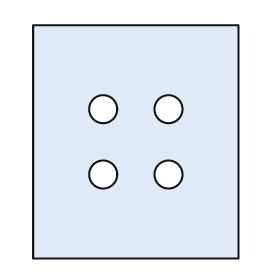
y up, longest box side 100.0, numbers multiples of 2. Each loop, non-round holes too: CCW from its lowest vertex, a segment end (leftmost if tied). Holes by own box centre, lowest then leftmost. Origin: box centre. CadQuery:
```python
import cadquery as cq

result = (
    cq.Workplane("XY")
    .moveTo(-44.0, -50.0)
    .lineTo(44.0, -50.0)
    .lineTo(44.0, 50.0)
    .lineTo(-44.0, 50.0)
    .close()
    .moveTo(-14.0, -14.0)
    .circle(6.0)
    .moveTo(14.0, -14.0)
    .circle(6.0)
    .moveTo(-14.0, 14.0)
    .circle(6.0)
    .moveTo(14.0, 14.0)
    .circle(6.0)
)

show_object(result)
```